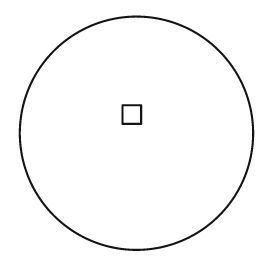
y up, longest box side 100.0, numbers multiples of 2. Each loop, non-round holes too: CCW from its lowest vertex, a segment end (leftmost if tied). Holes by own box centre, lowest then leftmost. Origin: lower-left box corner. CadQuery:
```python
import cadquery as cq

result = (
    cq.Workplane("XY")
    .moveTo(50.0, 50.0)
    .circle(50.0)
    .moveTo(44.0, 54.0)
    .lineTo(52.0, 54.0)
    .lineTo(52.0, 62.0)
    .lineTo(44.0, 62.0)
    .close()
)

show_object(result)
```